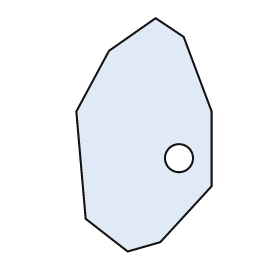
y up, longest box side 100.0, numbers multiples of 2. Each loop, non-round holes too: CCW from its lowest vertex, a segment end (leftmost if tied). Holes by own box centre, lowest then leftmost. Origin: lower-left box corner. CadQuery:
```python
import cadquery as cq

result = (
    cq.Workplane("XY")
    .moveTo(22.0, 0.0)
    .lineTo(36.0, 4.0)
    .lineTo(58.0, 28.0)
    .lineTo(58.0, 60.0)
    .lineTo(46.0, 92.0)
    .lineTo(34.0, 100.0)
    .lineTo(14.0, 86.0)
    .lineTo(0.0, 60.0)
    .lineTo(4.0, 14.0)
    .close()
    .moveTo(44.0, 40.0)
    .circle(6.0)
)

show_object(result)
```